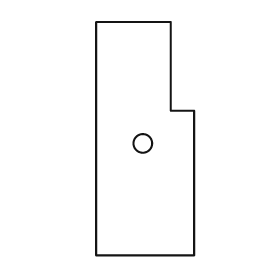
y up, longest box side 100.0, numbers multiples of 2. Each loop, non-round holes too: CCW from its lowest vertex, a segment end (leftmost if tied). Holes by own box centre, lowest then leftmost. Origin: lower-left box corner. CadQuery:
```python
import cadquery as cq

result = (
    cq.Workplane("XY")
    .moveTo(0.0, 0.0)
    .lineTo(42.0, 0.0)
    .lineTo(42.0, 62.0)
    .lineTo(32.0, 62.0)
    .lineTo(32.0, 100.0)
    .lineTo(0.0, 100.0)
    .close()
    .moveTo(20.0, 48.0)
    .circle(4.0)
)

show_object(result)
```